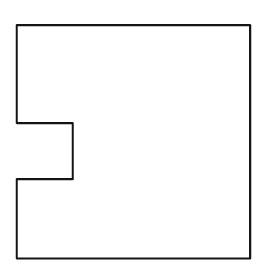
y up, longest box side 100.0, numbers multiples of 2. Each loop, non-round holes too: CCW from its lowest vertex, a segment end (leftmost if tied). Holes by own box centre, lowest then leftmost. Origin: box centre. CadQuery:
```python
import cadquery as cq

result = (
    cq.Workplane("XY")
    .moveTo(-50.0, -50.0)
    .lineTo(50.0, -50.0)
    .lineTo(50.0, 50.0)
    .lineTo(-50.0, 50.0)
    .lineTo(-50.0, 8.0)
    .lineTo(-26.0, 8.0)
    .lineTo(-26.0, -16.0)
    .lineTo(-50.0, -16.0)
    .close()
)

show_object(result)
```